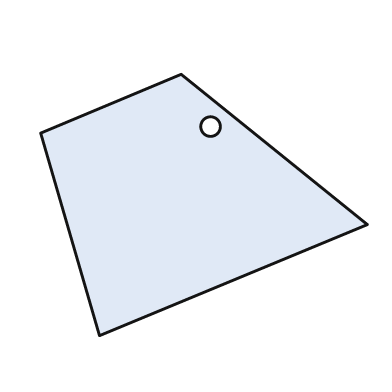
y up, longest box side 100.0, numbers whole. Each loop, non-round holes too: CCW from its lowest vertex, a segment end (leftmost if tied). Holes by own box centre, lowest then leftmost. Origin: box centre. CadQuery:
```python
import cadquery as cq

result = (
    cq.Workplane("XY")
    .moveTo(-32.0, -40.0)
    .lineTo(50.0, -6.0)
    .lineTo(-7.0, 40.0)
    .lineTo(-50.0, 22.0)
    .close()
    .moveTo(2.0, 24.0)
    .circle(3.0)
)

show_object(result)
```